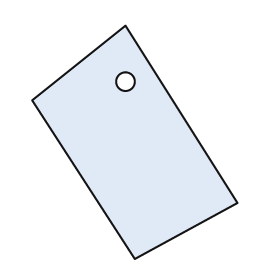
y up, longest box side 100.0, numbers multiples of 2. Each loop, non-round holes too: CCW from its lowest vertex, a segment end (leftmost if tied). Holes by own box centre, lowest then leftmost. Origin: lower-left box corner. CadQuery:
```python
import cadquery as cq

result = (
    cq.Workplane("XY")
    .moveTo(44.0, 0.0)
    .lineTo(88.0, 24.0)
    .lineTo(40.0, 100.0)
    .lineTo(0.0, 68.0)
    .close()
    .moveTo(40.0, 76.0)
    .circle(4.0)
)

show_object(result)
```